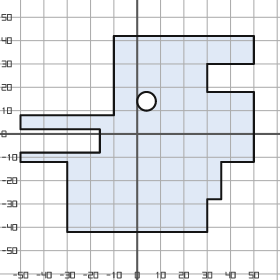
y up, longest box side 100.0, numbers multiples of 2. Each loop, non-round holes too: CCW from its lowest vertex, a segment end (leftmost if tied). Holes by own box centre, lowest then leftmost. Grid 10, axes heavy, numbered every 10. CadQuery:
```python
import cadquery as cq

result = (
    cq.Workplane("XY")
    .moveTo(-30.0, -42.0)
    .lineTo(30.0, -42.0)
    .lineTo(30.0, -28.0)
    .lineTo(36.0, -28.0)
    .lineTo(36.0, -12.0)
    .lineTo(50.0, -12.0)
    .lineTo(50.0, 18.0)
    .lineTo(30.0, 18.0)
    .lineTo(30.0, 30.0)
    .lineTo(50.0, 30.0)
    .lineTo(50.0, 42.0)
    .lineTo(-10.0, 42.0)
    .lineTo(-10.0, 8.0)
    .lineTo(-50.0, 8.0)
    .lineTo(-50.0, 2.0)
    .lineTo(-16.0, 2.0)
    .lineTo(-16.0, -8.0)
    .lineTo(-50.0, -8.0)
    .lineTo(-50.0, -12.0)
    .lineTo(-30.0, -12.0)
    .close()
    .moveTo(4.0, 14.0)
    .circle(4.0)
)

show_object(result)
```